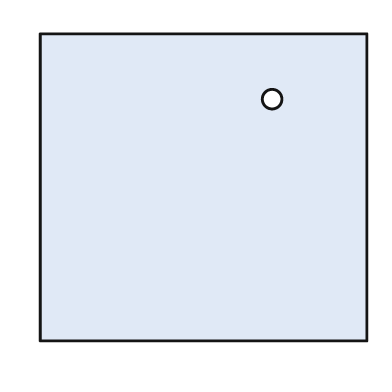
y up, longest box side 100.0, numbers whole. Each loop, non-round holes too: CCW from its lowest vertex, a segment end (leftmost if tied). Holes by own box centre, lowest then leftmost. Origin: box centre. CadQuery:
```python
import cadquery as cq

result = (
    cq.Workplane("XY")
    .moveTo(-50.0, -47.0)
    .lineTo(50.0, -47.0)
    .lineTo(50.0, 47.0)
    .lineTo(-50.0, 47.0)
    .close()
    .moveTo(21.0, 27.0)
    .circle(3.0)
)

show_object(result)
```